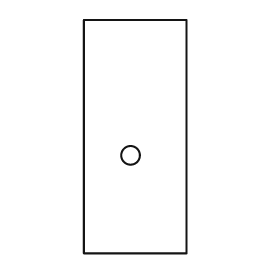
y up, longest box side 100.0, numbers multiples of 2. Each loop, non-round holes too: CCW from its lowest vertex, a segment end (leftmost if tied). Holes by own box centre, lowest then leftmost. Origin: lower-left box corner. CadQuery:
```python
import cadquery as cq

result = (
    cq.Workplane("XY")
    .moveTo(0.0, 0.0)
    .lineTo(44.0, 0.0)
    .lineTo(44.0, 100.0)
    .lineTo(0.0, 100.0)
    .close()
    .moveTo(20.0, 42.0)
    .circle(4.0)
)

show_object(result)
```